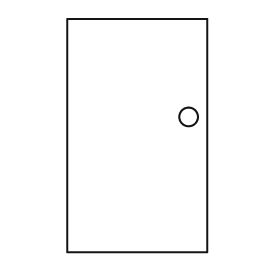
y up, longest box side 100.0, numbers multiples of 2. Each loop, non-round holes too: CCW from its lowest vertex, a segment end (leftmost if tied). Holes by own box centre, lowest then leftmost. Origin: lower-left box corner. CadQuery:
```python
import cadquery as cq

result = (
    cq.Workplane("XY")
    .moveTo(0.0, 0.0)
    .lineTo(60.0, 0.0)
    .lineTo(60.0, 100.0)
    .lineTo(0.0, 100.0)
    .close()
    .moveTo(52.0, 58.0)
    .circle(4.0)
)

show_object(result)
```